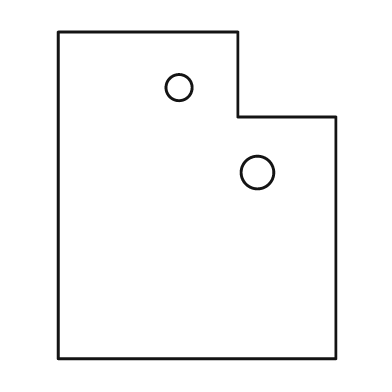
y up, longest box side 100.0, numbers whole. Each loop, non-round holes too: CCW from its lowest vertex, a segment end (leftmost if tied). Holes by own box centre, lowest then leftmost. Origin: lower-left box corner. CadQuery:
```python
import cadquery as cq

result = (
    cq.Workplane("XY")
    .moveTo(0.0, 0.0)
    .lineTo(85.0, 0.0)
    .lineTo(85.0, 74.0)
    .lineTo(55.0, 74.0)
    .lineTo(55.0, 100.0)
    .lineTo(0.0, 100.0)
    .close()
    .moveTo(61.0, 57.0)
    .circle(5.0)
    .moveTo(37.0, 83.0)
    .circle(4.0)
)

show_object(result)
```